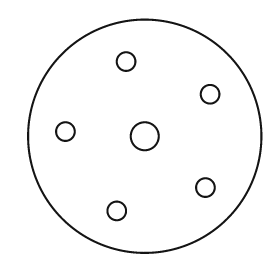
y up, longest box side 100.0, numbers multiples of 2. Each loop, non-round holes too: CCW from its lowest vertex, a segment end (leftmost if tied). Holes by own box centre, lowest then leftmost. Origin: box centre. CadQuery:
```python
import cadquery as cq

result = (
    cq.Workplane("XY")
    .moveTo(0.0, 0.0)
    .circle(50.0)
    .moveTo(-12.0, -32.0)
    .circle(4.0)
    .moveTo(26.0, -22.0)
    .circle(4.0)
    .moveTo(0.0, 0.0)
    .circle(6.0)
    .moveTo(-34.0, 2.0)
    .circle(4.0)
    .moveTo(28.0, 18.0)
    .circle(4.0)
    .moveTo(-8.0, 32.0)
    .circle(4.0)
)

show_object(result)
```